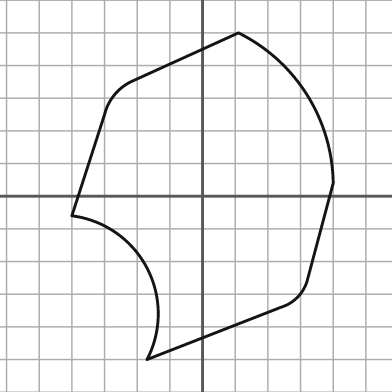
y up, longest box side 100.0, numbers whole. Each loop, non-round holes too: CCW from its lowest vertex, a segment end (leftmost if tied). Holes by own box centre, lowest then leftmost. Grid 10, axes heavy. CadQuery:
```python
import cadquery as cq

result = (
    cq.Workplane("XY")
    .moveTo(-17.0, -50.0)
    .lineTo(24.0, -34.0)
    .threePointArc((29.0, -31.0), (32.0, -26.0))
    .lineTo(40.0, 4.0)
    .threePointArc((32.0, 31.0), (11.0, 50.0))
    .lineTo(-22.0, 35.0)
    .threePointArc((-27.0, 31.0), (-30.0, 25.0))
    .lineTo(-40.0, -6.0)
    .threePointArc((-17.0, -22.0), (-17.0, -50.0))
    .close()
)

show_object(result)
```